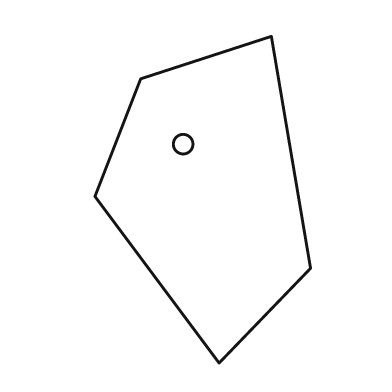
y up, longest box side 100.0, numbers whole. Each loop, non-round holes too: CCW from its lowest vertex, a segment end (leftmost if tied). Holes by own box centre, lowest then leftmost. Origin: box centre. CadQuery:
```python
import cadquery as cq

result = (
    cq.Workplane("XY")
    .moveTo(5.0, -50.0)
    .lineTo(33.0, -21.0)
    .lineTo(21.0, 50.0)
    .lineTo(-19.0, 37.0)
    .lineTo(-33.0, 1.0)
    .close()
    .moveTo(-6.0, 17.0)
    .circle(3.0)
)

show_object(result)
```